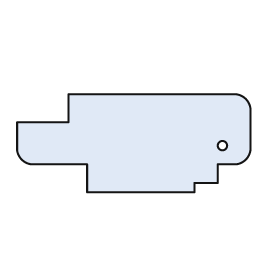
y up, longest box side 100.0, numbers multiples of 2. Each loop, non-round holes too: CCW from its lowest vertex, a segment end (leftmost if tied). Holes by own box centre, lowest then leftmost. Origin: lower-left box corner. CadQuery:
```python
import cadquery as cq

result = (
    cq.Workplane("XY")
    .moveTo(30.0, 0.0)
    .lineTo(76.0, 0.0)
    .lineTo(76.0, 4.0)
    .lineTo(86.0, 4.0)
    .lineTo(86.0, 12.0)
    .lineTo(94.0, 12.0)
    .threePointArc((98.0, 14.0), (100.0, 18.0))
    .lineTo(100.0, 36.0)
    .threePointArc((98.0, 40.0), (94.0, 42.0))
    .lineTo(22.0, 42.0)
    .lineTo(22.0, 30.0)
    .lineTo(0.0, 30.0)
    .lineTo(0.0, 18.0)
    .threePointArc((2.0, 14.0), (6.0, 12.0))
    .lineTo(30.0, 12.0)
    .close()
    .moveTo(88.0, 20.0)
    .circle(2.0)
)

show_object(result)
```